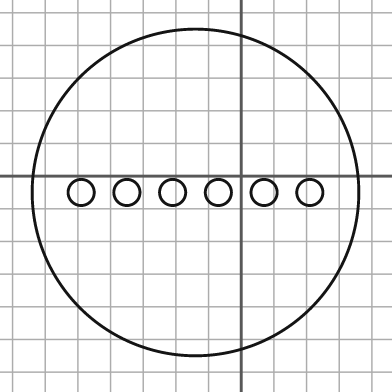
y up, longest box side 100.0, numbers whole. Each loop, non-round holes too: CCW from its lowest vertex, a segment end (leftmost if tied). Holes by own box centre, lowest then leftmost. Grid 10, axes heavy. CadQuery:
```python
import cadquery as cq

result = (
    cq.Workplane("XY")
    .moveTo(-14.0, -5.0)
    .circle(50.0)
    .moveTo(-49.0, -5.0)
    .circle(4.0)
    .moveTo(-35.0, -5.0)
    .circle(4.0)
    .moveTo(-21.0, -5.0)
    .circle(4.0)
    .moveTo(-7.0, -5.0)
    .circle(4.0)
    .moveTo(7.0, -5.0)
    .circle(4.0)
    .moveTo(21.0, -5.0)
    .circle(4.0)
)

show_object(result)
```